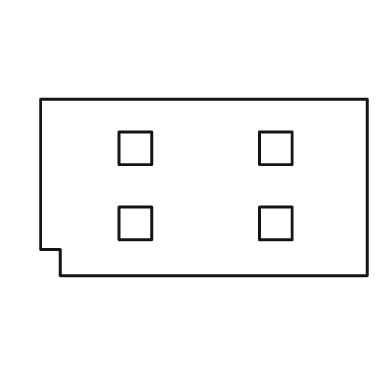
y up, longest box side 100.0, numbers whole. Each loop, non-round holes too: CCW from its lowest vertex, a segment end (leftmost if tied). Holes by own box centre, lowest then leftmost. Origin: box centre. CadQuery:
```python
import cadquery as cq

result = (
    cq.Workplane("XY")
    .moveTo(-44.0, -27.0)
    .lineTo(50.0, -27.0)
    .lineTo(50.0, 27.0)
    .lineTo(-50.0, 27.0)
    .lineTo(-50.0, -19.0)
    .lineTo(-44.0, -19.0)
    .close()
    .moveTo(-26.0, -16.0)
    .lineTo(-16.0, -16.0)
    .lineTo(-16.0, -6.0)
    .lineTo(-26.0, -6.0)
    .close()
    .moveTo(17.0, -16.0)
    .lineTo(27.0, -16.0)
    .lineTo(27.0, -6.0)
    .lineTo(17.0, -6.0)
    .close()
    .moveTo(-26.0, 7.0)
    .lineTo(-16.0, 7.0)
    .lineTo(-16.0, 17.0)
    .lineTo(-26.0, 17.0)
    .close()
    .moveTo(17.0, 7.0)
    .lineTo(27.0, 7.0)
    .lineTo(27.0, 17.0)
    .lineTo(17.0, 17.0)
    .close()
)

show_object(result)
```